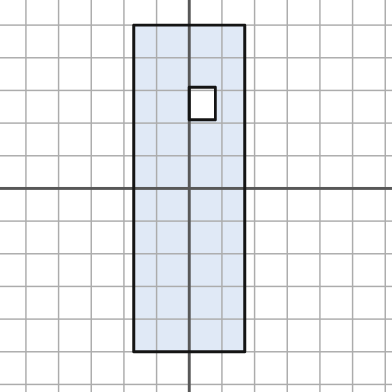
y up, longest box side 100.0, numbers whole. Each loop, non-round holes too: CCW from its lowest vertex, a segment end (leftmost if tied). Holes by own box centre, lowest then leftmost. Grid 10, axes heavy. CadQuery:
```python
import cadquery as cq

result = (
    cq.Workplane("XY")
    .moveTo(-17.0, -50.0)
    .lineTo(17.0, -50.0)
    .lineTo(17.0, 50.0)
    .lineTo(-17.0, 50.0)
    .close()
    .moveTo(0.0, 21.0)
    .lineTo(8.0, 21.0)
    .lineTo(8.0, 31.0)
    .lineTo(0.0, 31.0)
    .close()
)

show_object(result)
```